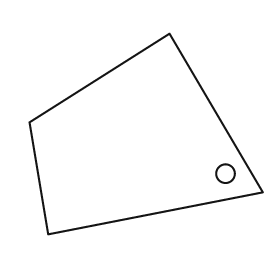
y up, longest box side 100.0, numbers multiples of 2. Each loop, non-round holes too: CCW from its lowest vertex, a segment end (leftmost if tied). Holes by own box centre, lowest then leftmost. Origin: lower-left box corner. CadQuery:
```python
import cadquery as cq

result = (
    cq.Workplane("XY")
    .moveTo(8.0, 0.0)
    .lineTo(100.0, 18.0)
    .lineTo(60.0, 86.0)
    .lineTo(0.0, 48.0)
    .close()
    .moveTo(84.0, 26.0)
    .circle(4.0)
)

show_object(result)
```